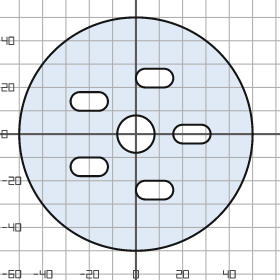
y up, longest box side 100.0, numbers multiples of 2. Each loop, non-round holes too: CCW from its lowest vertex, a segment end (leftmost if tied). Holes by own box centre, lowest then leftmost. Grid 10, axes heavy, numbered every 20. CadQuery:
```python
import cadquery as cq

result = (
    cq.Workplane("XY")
    .moveTo(0.0, 0.0)
    .circle(50.0)
    .moveTo(4.0, -28.0)
    .lineTo(12.0, -28.0)
    .threePointArc((16.0, -24.0), (12.0, -20.0))
    .lineTo(4.0, -20.0)
    .threePointArc((0.0, -24.0), (4.0, -28.0))
    .close()
    .moveTo(-24.0, -18.0)
    .lineTo(-16.0, -18.0)
    .threePointArc((-12.0, -14.0), (-16.0, -10.0))
    .lineTo(-24.0, -10.0)
    .threePointArc((-28.0, -14.0), (-24.0, -18.0))
    .close()
    .moveTo(0.0, 0.0)
    .circle(8.0)
    .moveTo(20.0, -4.0)
    .lineTo(28.0, -4.0)
    .threePointArc((32.0, 0.0), (28.0, 4.0))
    .lineTo(20.0, 4.0)
    .threePointArc((16.0, 0.0), (20.0, -4.0))
    .close()
    .moveTo(-24.0, 10.0)
    .lineTo(-16.0, 10.0)
    .threePointArc((-12.0, 14.0), (-16.0, 18.0))
    .lineTo(-24.0, 18.0)
    .threePointArc((-28.0, 14.0), (-24.0, 10.0))
    .close()
    .moveTo(4.0, 20.0)
    .lineTo(12.0, 20.0)
    .threePointArc((16.0, 24.0), (12.0, 28.0))
    .lineTo(4.0, 28.0)
    .threePointArc((0.0, 24.0), (4.0, 20.0))
    .close()
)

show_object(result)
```